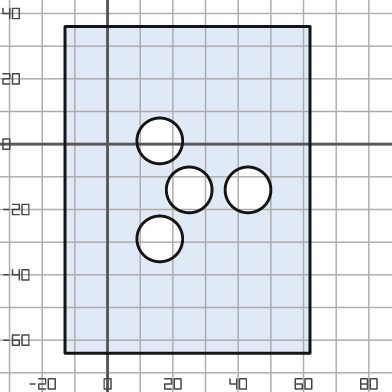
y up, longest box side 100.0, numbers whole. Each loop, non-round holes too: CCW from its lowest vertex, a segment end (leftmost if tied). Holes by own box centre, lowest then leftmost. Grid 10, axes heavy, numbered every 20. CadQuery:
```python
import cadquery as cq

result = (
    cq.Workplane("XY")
    .moveTo(-13.0, -64.0)
    .lineTo(62.0, -64.0)
    .lineTo(62.0, 36.0)
    .lineTo(-13.0, 36.0)
    .close()
    .moveTo(16.0, -29.0)
    .circle(7.0)
    .moveTo(25.0, -14.0)
    .circle(7.0)
    .moveTo(43.0, -14.0)
    .circle(7.0)
    .moveTo(16.0, 1.0)
    .circle(7.0)
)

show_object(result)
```